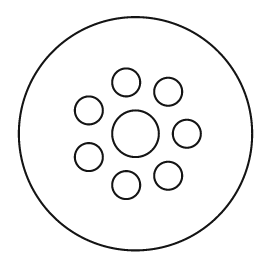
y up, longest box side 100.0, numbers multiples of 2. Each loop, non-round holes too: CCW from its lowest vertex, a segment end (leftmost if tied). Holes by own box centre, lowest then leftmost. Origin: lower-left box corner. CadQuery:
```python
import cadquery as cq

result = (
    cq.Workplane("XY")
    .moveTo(50.0, 50.0)
    .circle(50.0)
    .moveTo(46.0, 28.0)
    .circle(6.0)
    .moveTo(64.0, 32.0)
    .circle(6.0)
    .moveTo(30.0, 40.0)
    .circle(6.0)
    .moveTo(50.0, 50.0)
    .circle(10.0)
    .moveTo(72.0, 50.0)
    .circle(6.0)
    .moveTo(30.0, 60.0)
    .circle(6.0)
    .moveTo(64.0, 68.0)
    .circle(6.0)
    .moveTo(46.0, 72.0)
    .circle(6.0)
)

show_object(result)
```